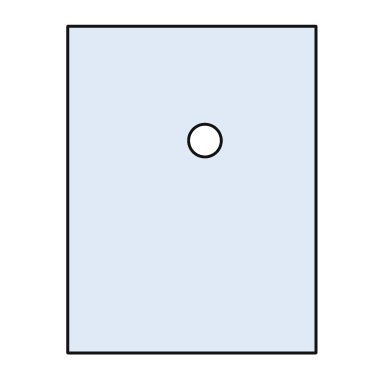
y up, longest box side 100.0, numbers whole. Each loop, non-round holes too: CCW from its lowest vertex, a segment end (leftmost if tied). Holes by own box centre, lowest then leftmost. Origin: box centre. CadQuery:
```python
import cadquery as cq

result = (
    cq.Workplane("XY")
    .moveTo(-38.0, -50.0)
    .lineTo(38.0, -50.0)
    .lineTo(38.0, 50.0)
    .lineTo(-38.0, 50.0)
    .close()
    .moveTo(4.0, 15.0)
    .circle(5.0)
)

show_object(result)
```